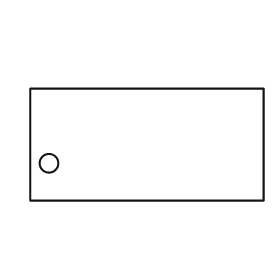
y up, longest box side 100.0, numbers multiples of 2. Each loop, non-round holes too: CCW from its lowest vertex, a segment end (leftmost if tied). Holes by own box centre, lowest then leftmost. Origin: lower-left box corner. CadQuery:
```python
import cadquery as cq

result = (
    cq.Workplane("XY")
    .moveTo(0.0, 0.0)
    .lineTo(100.0, 0.0)
    .lineTo(100.0, 48.0)
    .lineTo(0.0, 48.0)
    .close()
    .moveTo(8.0, 16.0)
    .circle(4.0)
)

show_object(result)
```